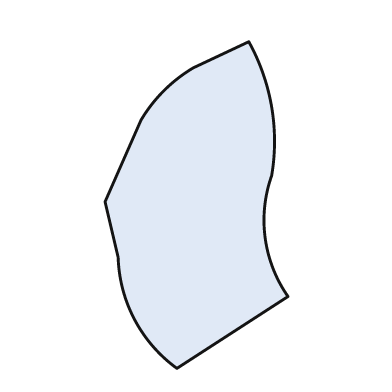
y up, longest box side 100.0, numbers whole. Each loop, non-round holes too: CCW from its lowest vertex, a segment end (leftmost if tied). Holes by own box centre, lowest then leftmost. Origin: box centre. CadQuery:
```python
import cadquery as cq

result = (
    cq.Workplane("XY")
    .moveTo(-6.0, -50.0)
    .lineTo(28.0, -28.0)
    .threePointArc((21.0, -10.0), (23.0, 9.0))
    .threePointArc((23.0, 30.0), (16.0, 50.0))
    .lineTo(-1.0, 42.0)
    .threePointArc((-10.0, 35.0), (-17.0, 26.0))
    .lineTo(-28.0, 1.0)
    .lineTo(-24.0, -16.0)
    .threePointArc((-19.0, -35.0), (-6.0, -50.0))
    .close()
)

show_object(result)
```